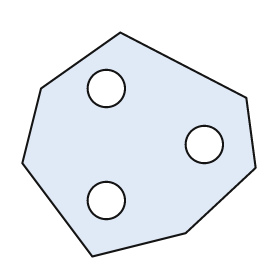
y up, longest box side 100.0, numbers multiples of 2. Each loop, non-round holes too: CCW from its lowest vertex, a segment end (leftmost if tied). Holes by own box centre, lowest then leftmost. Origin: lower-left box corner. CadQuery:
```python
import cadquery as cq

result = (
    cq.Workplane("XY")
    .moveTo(30.0, 0.0)
    .lineTo(70.0, 10.0)
    .lineTo(100.0, 38.0)
    .lineTo(96.0, 68.0)
    .lineTo(42.0, 96.0)
    .lineTo(8.0, 72.0)
    .lineTo(0.0, 40.0)
    .close()
    .moveTo(36.0, 24.0)
    .circle(8.0)
    .moveTo(78.0, 48.0)
    .circle(8.0)
    .moveTo(36.0, 72.0)
    .circle(8.0)
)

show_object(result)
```